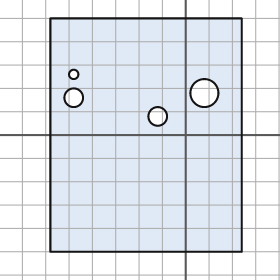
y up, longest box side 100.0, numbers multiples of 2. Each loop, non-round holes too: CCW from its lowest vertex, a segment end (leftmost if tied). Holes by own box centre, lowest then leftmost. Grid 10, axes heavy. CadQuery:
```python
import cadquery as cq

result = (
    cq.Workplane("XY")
    .moveTo(-58.0, -50.0)
    .lineTo(24.0, -50.0)
    .lineTo(24.0, 50.0)
    .lineTo(-58.0, 50.0)
    .close()
    .moveTo(-12.0, 8.0)
    .circle(4.0)
    .moveTo(-48.0, 16.0)
    .circle(4.0)
    .moveTo(8.0, 18.0)
    .circle(6.0)
    .moveTo(-48.0, 26.0)
    .circle(2.0)
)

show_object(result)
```